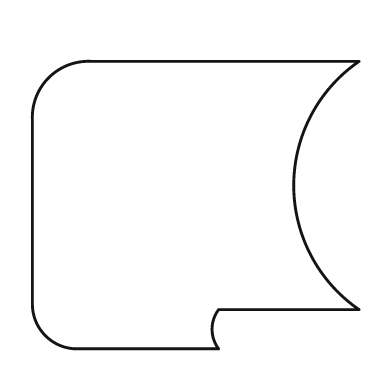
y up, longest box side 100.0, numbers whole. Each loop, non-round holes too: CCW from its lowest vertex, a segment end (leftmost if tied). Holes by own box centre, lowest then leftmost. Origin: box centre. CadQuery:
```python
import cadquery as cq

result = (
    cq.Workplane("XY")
    .moveTo(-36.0, -44.0)
    .lineTo(7.0, -44.0)
    .threePointArc((5.0, -38.0), (7.0, -32.0))
    .lineTo(50.0, -32.0)
    .threePointArc((30.0, 6.0), (50.0, 44.0))
    .lineTo(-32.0, 44.0)
    .threePointArc((-45.0, 39.0), (-50.0, 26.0))
    .lineTo(-50.0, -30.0)
    .threePointArc((-46.0, -40.0), (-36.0, -44.0))
    .close()
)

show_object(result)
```